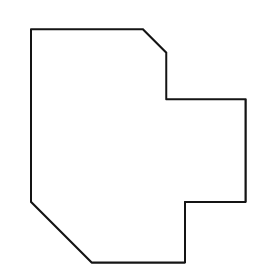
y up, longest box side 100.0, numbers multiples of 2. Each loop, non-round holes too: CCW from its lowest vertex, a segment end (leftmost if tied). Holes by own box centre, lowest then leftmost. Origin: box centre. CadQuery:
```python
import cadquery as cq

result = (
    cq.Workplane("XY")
    .moveTo(-20.0, -50.0)
    .lineTo(20.0, -50.0)
    .lineTo(20.0, -24.0)
    .lineTo(46.0, -24.0)
    .lineTo(46.0, 20.0)
    .lineTo(12.0, 20.0)
    .lineTo(12.0, 40.0)
    .lineTo(2.0, 50.0)
    .lineTo(-46.0, 50.0)
    .lineTo(-46.0, -24.0)
    .close()
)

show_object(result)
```